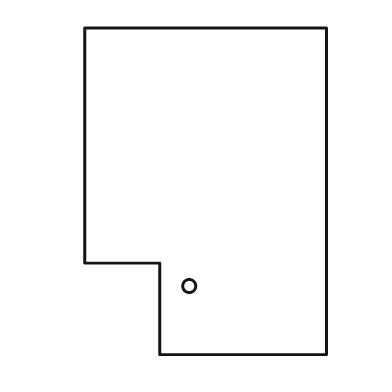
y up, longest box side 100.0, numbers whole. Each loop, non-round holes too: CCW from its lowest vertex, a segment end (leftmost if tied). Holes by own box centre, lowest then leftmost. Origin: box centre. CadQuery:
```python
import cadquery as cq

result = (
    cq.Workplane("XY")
    .moveTo(-14.0, -50.0)
    .lineTo(37.0, -50.0)
    .lineTo(37.0, 50.0)
    .lineTo(-37.0, 50.0)
    .lineTo(-37.0, -22.0)
    .lineTo(-14.0, -22.0)
    .close()
    .moveTo(-5.0, -29.0)
    .circle(2.0)
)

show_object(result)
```